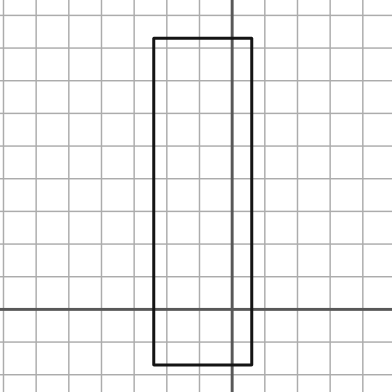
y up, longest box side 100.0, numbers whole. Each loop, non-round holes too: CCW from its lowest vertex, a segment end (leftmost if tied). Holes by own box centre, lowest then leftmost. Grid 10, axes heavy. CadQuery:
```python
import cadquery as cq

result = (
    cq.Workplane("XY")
    .moveTo(-24.0, -17.0)
    .lineTo(6.0, -17.0)
    .lineTo(6.0, 83.0)
    .lineTo(-24.0, 83.0)
    .close()
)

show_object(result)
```